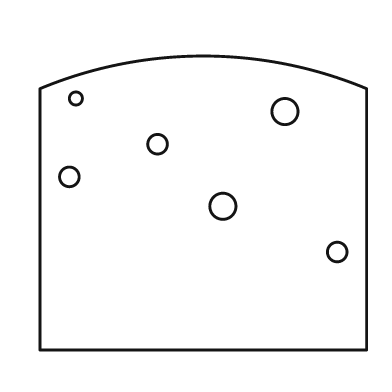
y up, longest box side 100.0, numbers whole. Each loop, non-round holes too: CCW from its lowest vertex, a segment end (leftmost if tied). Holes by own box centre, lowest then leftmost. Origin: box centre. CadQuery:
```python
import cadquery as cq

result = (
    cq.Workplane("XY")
    .moveTo(-50.0, -45.0)
    .lineTo(50.0, -45.0)
    .lineTo(50.0, 35.0)
    .threePointArc((0.0, 45.0), (-50.0, 35.0))
    .close()
    .moveTo(41.0, -15.0)
    .circle(3.0)
    .moveTo(6.0, -1.0)
    .circle(4.0)
    .moveTo(-41.0, 8.0)
    .circle(3.0)
    .moveTo(-14.0, 18.0)
    .circle(3.0)
    .moveTo(25.0, 28.0)
    .circle(4.0)
    .moveTo(-39.0, 32.0)
    .circle(2.0)
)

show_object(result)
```